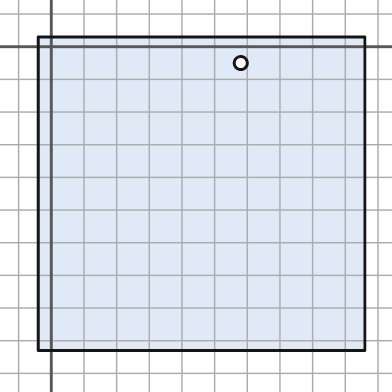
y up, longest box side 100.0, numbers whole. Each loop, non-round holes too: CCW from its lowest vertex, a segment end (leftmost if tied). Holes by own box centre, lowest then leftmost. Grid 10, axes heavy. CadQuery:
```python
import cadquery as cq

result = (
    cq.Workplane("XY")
    .moveTo(-4.0, -93.0)
    .lineTo(96.0, -93.0)
    .lineTo(96.0, 3.0)
    .lineTo(-4.0, 3.0)
    .close()
    .moveTo(58.0, -5.0)
    .circle(2.0)
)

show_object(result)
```